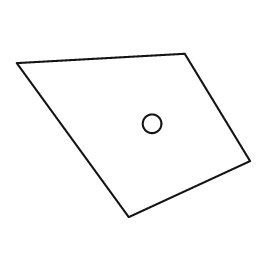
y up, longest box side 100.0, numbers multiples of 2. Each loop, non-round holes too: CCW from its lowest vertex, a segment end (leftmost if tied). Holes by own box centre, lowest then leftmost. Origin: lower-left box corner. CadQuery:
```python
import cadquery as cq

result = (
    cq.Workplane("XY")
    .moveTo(48.0, 0.0)
    .lineTo(100.0, 24.0)
    .lineTo(72.0, 70.0)
    .lineTo(0.0, 66.0)
    .close()
    .moveTo(58.0, 40.0)
    .circle(4.0)
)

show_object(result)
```